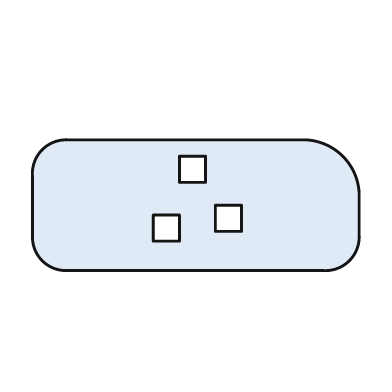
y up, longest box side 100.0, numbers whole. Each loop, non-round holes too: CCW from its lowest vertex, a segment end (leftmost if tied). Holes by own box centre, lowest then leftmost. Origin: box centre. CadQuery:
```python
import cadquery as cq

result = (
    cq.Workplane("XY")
    .moveTo(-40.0, -20.0)
    .lineTo(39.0, -20.0)
    .threePointArc((47.0, -17.0), (50.0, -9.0))
    .lineTo(50.0, 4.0)
    .threePointArc((45.0, 15.0), (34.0, 20.0))
    .lineTo(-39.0, 20.0)
    .threePointArc((-47.0, 17.0), (-50.0, 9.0))
    .lineTo(-50.0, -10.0)
    .threePointArc((-47.0, -17.0), (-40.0, -20.0))
    .close()
    .moveTo(-13.0, -11.0)
    .lineTo(-5.0, -11.0)
    .lineTo(-5.0, -3.0)
    .lineTo(-13.0, -3.0)
    .close()
    .moveTo(6.0, -8.0)
    .lineTo(14.0, -8.0)
    .lineTo(14.0, 0.0)
    .lineTo(6.0, 0.0)
    .close()
    .moveTo(-5.0, 7.0)
    .lineTo(3.0, 7.0)
    .lineTo(3.0, 15.0)
    .lineTo(-5.0, 15.0)
    .close()
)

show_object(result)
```